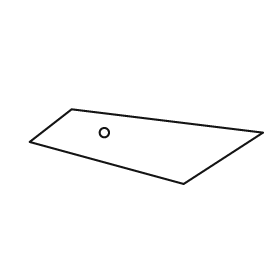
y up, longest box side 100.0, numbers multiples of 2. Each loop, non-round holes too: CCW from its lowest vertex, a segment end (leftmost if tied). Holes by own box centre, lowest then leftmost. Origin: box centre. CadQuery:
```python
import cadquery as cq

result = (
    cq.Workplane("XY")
    .moveTo(16.0, -16.0)
    .lineTo(50.0, 6.0)
    .lineTo(-32.0, 16.0)
    .lineTo(-50.0, 2.0)
    .close()
    .moveTo(-18.0, 6.0)
    .circle(2.0)
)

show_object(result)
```